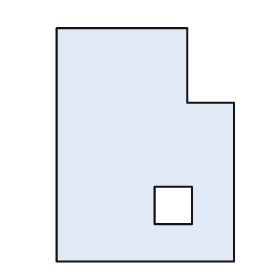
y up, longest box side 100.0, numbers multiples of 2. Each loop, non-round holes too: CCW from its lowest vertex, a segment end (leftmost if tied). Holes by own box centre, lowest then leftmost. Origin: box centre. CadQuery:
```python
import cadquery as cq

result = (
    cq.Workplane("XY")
    .moveTo(-38.0, -50.0)
    .lineTo(38.0, -50.0)
    .lineTo(38.0, 18.0)
    .lineTo(18.0, 18.0)
    .lineTo(18.0, 50.0)
    .lineTo(-38.0, 50.0)
    .close()
    .moveTo(4.0, -34.0)
    .lineTo(20.0, -34.0)
    .lineTo(20.0, -18.0)
    .lineTo(4.0, -18.0)
    .close()
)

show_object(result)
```